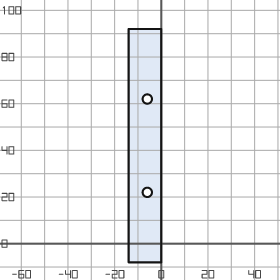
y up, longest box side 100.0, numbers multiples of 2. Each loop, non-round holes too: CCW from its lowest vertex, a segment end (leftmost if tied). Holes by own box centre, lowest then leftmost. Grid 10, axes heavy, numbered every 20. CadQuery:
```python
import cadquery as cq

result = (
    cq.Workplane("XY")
    .moveTo(-14.0, -8.0)
    .lineTo(0.0, -8.0)
    .lineTo(0.0, 92.0)
    .lineTo(-14.0, 92.0)
    .close()
    .moveTo(-6.0, 22.0)
    .circle(2.0)
    .moveTo(-6.0, 62.0)
    .circle(2.0)
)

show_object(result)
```